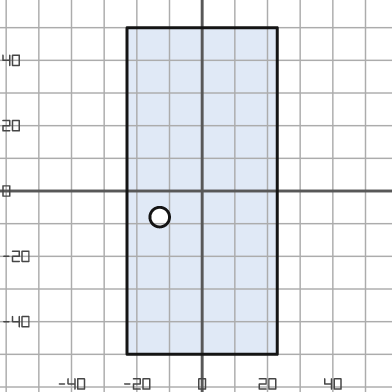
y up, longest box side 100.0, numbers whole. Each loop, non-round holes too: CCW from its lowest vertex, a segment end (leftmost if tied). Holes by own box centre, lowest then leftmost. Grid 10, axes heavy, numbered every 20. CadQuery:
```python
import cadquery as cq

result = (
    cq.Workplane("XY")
    .moveTo(-23.0, -50.0)
    .lineTo(23.0, -50.0)
    .lineTo(23.0, 50.0)
    .lineTo(-23.0, 50.0)
    .close()
    .moveTo(-13.0, -8.0)
    .circle(3.0)
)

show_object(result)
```